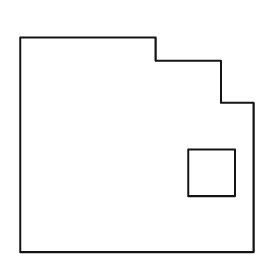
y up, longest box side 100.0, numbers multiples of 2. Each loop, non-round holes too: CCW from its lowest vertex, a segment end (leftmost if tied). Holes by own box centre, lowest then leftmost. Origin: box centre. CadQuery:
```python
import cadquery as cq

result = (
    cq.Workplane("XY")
    .moveTo(-50.0, -46.0)
    .lineTo(50.0, -46.0)
    .lineTo(50.0, 18.0)
    .lineTo(36.0, 18.0)
    .lineTo(36.0, 36.0)
    .lineTo(8.0, 36.0)
    .lineTo(8.0, 46.0)
    .lineTo(-50.0, 46.0)
    .close()
    .moveTo(22.0, -22.0)
    .lineTo(42.0, -22.0)
    .lineTo(42.0, -2.0)
    .lineTo(22.0, -2.0)
    .close()
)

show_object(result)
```